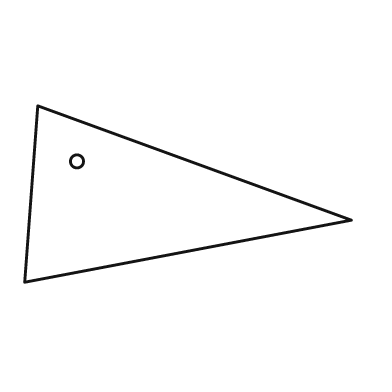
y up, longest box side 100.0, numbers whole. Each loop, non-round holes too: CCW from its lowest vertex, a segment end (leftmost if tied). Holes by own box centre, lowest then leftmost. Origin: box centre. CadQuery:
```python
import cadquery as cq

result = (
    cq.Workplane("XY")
    .moveTo(-50.0, -27.0)
    .lineTo(50.0, -8.0)
    .lineTo(-46.0, 27.0)
    .close()
    .moveTo(-34.0, 10.0)
    .circle(2.0)
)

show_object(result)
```